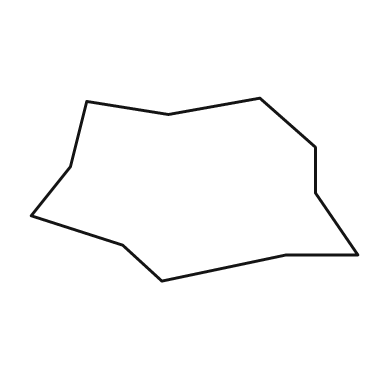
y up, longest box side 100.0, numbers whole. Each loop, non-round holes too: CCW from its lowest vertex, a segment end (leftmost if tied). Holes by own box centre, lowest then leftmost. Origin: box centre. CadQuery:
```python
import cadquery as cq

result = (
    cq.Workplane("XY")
    .moveTo(-10.0, -28.0)
    .lineTo(28.0, -20.0)
    .lineTo(50.0, -20.0)
    .lineTo(37.0, -1.0)
    .lineTo(37.0, 13.0)
    .lineTo(20.0, 28.0)
    .lineTo(-8.0, 23.0)
    .lineTo(-33.0, 27.0)
    .lineTo(-38.0, 7.0)
    .lineTo(-50.0, -8.0)
    .lineTo(-22.0, -17.0)
    .close()
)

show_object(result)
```